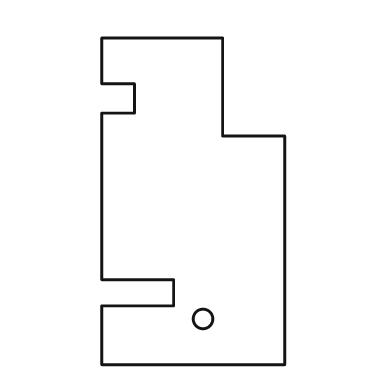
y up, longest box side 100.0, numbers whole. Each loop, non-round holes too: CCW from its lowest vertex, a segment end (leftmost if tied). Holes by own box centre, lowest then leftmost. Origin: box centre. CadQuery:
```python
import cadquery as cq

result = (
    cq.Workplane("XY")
    .moveTo(-28.0, -50.0)
    .lineTo(28.0, -50.0)
    .lineTo(28.0, 20.0)
    .lineTo(9.0, 20.0)
    .lineTo(9.0, 50.0)
    .lineTo(-28.0, 50.0)
    .lineTo(-28.0, 36.0)
    .lineTo(-18.0, 36.0)
    .lineTo(-18.0, 27.0)
    .lineTo(-28.0, 27.0)
    .lineTo(-28.0, -24.0)
    .lineTo(-6.0, -24.0)
    .lineTo(-6.0, -32.0)
    .lineTo(-28.0, -32.0)
    .close()
    .moveTo(3.0, -36.0)
    .circle(3.0)
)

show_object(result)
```